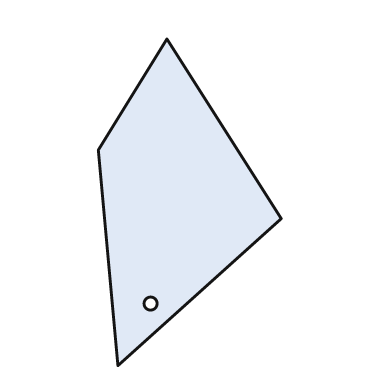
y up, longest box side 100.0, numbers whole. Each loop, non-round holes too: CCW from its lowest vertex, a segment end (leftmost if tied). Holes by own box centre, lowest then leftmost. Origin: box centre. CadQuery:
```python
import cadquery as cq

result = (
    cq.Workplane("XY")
    .moveTo(-22.0, -50.0)
    .lineTo(28.0, -5.0)
    .lineTo(-7.0, 50.0)
    .lineTo(-28.0, 16.0)
    .close()
    .moveTo(-12.0, -31.0)
    .circle(2.0)
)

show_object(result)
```